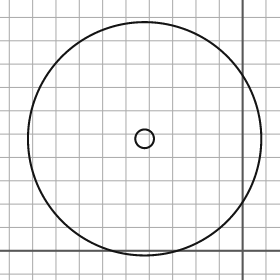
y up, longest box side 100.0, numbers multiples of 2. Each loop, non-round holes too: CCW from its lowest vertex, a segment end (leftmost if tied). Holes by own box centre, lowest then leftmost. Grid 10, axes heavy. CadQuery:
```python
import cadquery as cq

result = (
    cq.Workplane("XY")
    .moveTo(-42.0, 48.0)
    .circle(50.0)
    .moveTo(-42.0, 48.0)
    .circle(4.0)
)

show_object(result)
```